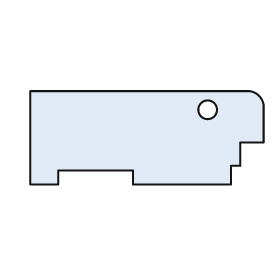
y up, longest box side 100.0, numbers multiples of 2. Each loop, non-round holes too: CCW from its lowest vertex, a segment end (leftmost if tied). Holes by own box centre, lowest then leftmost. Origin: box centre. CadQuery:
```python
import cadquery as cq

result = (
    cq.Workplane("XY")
    .moveTo(-50.0, -20.0)
    .lineTo(-38.0, -20.0)
    .lineTo(-38.0, -14.0)
    .lineTo(-6.0, -14.0)
    .lineTo(-6.0, -20.0)
    .lineTo(36.0, -20.0)
    .lineTo(36.0, -12.0)
    .lineTo(40.0, -12.0)
    .lineTo(40.0, -2.0)
    .lineTo(50.0, -2.0)
    .lineTo(50.0, 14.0)
    .threePointArc((48.0, 18.0), (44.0, 20.0))
    .lineTo(-50.0, 20.0)
    .close()
    .moveTo(26.0, 12.0)
    .circle(4.0)
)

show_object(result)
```